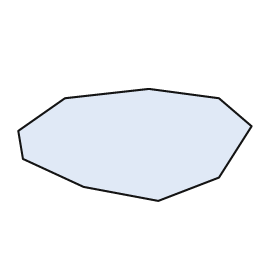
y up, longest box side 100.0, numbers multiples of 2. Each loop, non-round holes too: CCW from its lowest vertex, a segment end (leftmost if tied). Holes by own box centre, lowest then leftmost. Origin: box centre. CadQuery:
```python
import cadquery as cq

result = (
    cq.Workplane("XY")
    .moveTo(10.0, -24.0)
    .lineTo(36.0, -14.0)
    .lineTo(50.0, 8.0)
    .lineTo(36.0, 20.0)
    .lineTo(6.0, 24.0)
    .lineTo(-30.0, 20.0)
    .lineTo(-50.0, 6.0)
    .lineTo(-48.0, -6.0)
    .lineTo(-22.0, -18.0)
    .close()
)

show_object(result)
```